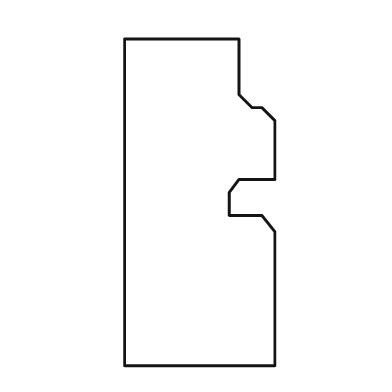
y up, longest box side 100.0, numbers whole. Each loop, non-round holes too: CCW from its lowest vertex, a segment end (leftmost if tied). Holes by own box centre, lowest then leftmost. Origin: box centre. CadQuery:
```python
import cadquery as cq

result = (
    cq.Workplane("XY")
    .moveTo(-23.0, -50.0)
    .lineTo(23.0, -50.0)
    .lineTo(23.0, -9.0)
    .lineTo(19.0, -4.0)
    .lineTo(9.0, -4.0)
    .lineTo(9.0, 3.0)
    .lineTo(12.0, 7.0)
    .lineTo(23.0, 7.0)
    .lineTo(23.0, 25.0)
    .lineTo(19.0, 29.0)
    .lineTo(16.0, 29.0)
    .lineTo(12.0, 33.0)
    .lineTo(12.0, 50.0)
    .lineTo(-23.0, 50.0)
    .close()
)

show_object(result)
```